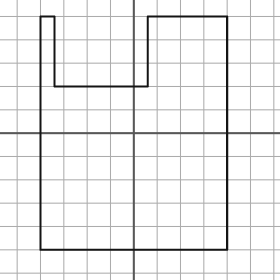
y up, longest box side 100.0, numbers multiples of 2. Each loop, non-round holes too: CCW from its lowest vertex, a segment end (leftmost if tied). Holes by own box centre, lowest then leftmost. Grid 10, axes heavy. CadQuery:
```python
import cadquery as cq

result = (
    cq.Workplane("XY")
    .moveTo(-40.0, -50.0)
    .lineTo(40.0, -50.0)
    .lineTo(40.0, 50.0)
    .lineTo(6.0, 50.0)
    .lineTo(6.0, 20.0)
    .lineTo(-34.0, 20.0)
    .lineTo(-34.0, 50.0)
    .lineTo(-40.0, 50.0)
    .close()
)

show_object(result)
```